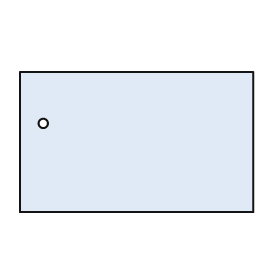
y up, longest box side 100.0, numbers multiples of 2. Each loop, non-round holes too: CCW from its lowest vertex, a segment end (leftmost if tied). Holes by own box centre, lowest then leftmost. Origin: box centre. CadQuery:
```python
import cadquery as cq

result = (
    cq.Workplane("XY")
    .moveTo(-50.0, -30.0)
    .lineTo(50.0, -30.0)
    .lineTo(50.0, 30.0)
    .lineTo(-50.0, 30.0)
    .close()
    .moveTo(-40.0, 8.0)
    .circle(2.0)
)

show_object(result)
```